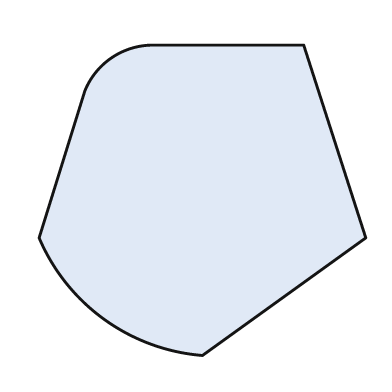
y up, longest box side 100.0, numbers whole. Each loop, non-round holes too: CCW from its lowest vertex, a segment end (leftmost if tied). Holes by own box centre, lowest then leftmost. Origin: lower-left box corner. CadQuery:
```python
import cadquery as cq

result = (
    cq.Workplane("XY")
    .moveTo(50.0, 0.0)
    .lineTo(100.0, 36.0)
    .lineTo(81.0, 95.0)
    .lineTo(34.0, 95.0)
    .threePointArc((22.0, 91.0), (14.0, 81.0))
    .lineTo(0.0, 36.0)
    .threePointArc((20.0, 11.0), (50.0, 0.0))
    .close()
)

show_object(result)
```